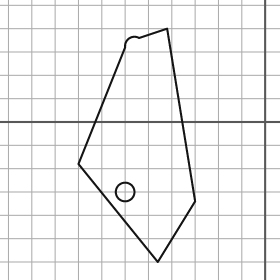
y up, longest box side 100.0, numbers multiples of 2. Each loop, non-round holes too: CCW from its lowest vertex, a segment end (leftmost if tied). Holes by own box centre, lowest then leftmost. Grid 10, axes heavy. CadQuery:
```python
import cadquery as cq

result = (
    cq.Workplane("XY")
    .moveTo(-46.0, -60.0)
    .lineTo(-30.0, -34.0)
    .lineTo(-42.0, 40.0)
    .lineTo(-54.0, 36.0)
    .threePointArc((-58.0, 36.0), (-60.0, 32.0))
    .lineTo(-80.0, -18.0)
    .close()
    .moveTo(-60.0, -30.0)
    .circle(4.0)
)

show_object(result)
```